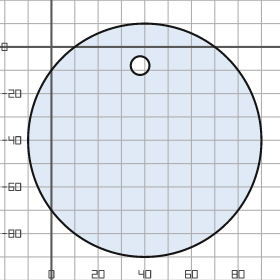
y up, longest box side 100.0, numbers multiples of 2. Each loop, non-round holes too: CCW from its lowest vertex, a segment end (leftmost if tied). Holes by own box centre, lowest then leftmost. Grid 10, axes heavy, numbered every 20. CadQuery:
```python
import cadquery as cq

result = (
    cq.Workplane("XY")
    .moveTo(40.0, -40.0)
    .circle(50.0)
    .moveTo(38.0, -8.0)
    .circle(4.0)
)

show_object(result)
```